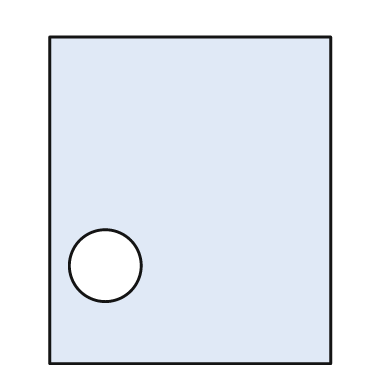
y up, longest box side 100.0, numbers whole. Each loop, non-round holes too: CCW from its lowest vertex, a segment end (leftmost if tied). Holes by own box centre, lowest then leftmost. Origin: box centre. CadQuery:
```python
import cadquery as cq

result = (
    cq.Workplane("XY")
    .moveTo(-43.0, -50.0)
    .lineTo(43.0, -50.0)
    .lineTo(43.0, 50.0)
    .lineTo(-43.0, 50.0)
    .close()
    .moveTo(-26.0, -20.0)
    .circle(11.0)
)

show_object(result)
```